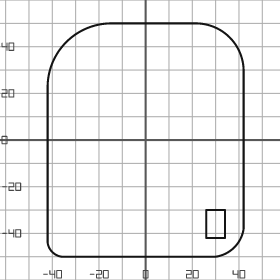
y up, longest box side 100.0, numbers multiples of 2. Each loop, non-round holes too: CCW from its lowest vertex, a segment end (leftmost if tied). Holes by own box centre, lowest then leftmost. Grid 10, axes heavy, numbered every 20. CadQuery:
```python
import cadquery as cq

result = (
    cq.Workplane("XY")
    .moveTo(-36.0, -50.0)
    .lineTo(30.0, -50.0)
    .threePointArc((38.0, -46.0), (42.0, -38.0))
    .lineTo(42.0, 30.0)
    .threePointArc((36.0, 44.0), (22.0, 50.0))
    .lineTo(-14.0, 50.0)
    .threePointArc((-34.0, 42.0), (-42.0, 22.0))
    .lineTo(-42.0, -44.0)
    .threePointArc((-40.0, -48.0), (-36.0, -50.0))
    .close()
    .moveTo(26.0, -42.0)
    .lineTo(34.0, -42.0)
    .lineTo(34.0, -30.0)
    .lineTo(26.0, -30.0)
    .close()
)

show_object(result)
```